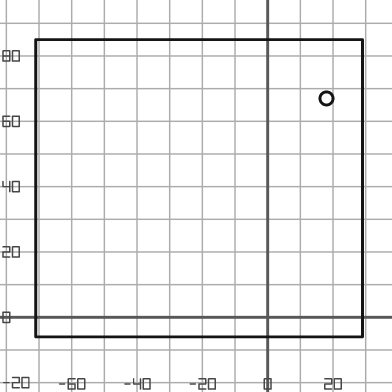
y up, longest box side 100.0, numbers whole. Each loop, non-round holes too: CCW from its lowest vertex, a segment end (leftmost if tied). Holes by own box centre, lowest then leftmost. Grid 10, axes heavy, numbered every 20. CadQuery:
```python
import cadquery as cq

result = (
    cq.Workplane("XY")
    .moveTo(-71.0, -6.0)
    .lineTo(29.0, -6.0)
    .lineTo(29.0, 85.0)
    .lineTo(-71.0, 85.0)
    .close()
    .moveTo(18.0, 67.0)
    .circle(2.0)
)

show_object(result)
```